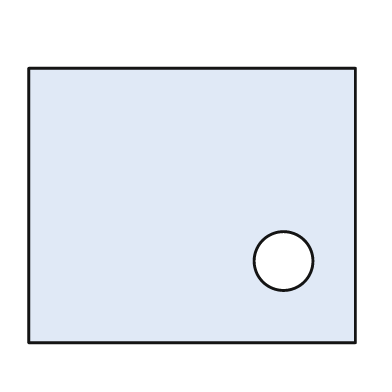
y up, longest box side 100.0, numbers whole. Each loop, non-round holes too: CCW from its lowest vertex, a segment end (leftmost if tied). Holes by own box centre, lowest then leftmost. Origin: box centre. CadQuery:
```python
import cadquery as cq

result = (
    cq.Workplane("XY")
    .moveTo(-50.0, -42.0)
    .lineTo(50.0, -42.0)
    .lineTo(50.0, 42.0)
    .lineTo(-50.0, 42.0)
    .close()
    .moveTo(28.0, -17.0)
    .circle(9.0)
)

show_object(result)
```